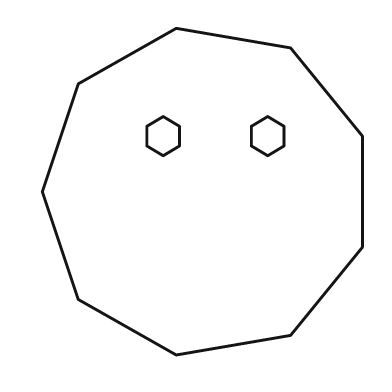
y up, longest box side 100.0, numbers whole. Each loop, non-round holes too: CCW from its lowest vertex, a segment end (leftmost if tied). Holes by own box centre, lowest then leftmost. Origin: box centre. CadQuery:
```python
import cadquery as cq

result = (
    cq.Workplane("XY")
    .moveTo(-8.0, -50.0)
    .lineTo(27.0, -44.0)
    .lineTo(49.0, -17.0)
    .lineTo(49.0, 17.0)
    .lineTo(27.0, 44.0)
    .lineTo(-8.0, 50.0)
    .lineTo(-38.0, 33.0)
    .lineTo(-49.0, 0.0)
    .lineTo(-38.0, -33.0)
    .close()
    .moveTo(-12.0, 11.0)
    .lineTo(-7.0, 14.0)
    .lineTo(-7.0, 20.0)
    .lineTo(-12.0, 23.0)
    .lineTo(-17.0, 20.0)
    .lineTo(-17.0, 14.0)
    .close()
    .moveTo(20.0, 11.0)
    .lineTo(25.0, 14.0)
    .lineTo(25.0, 20.0)
    .lineTo(20.0, 23.0)
    .lineTo(15.0, 20.0)
    .lineTo(15.0, 14.0)
    .close()
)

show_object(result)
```